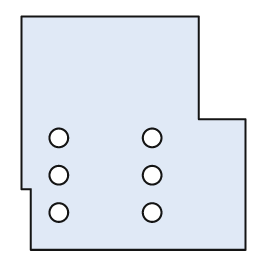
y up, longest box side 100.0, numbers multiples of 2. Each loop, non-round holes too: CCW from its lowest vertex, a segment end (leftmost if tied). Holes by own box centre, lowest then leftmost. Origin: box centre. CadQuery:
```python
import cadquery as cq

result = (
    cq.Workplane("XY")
    .moveTo(-44.0, -50.0)
    .lineTo(48.0, -50.0)
    .lineTo(48.0, 6.0)
    .lineTo(28.0, 6.0)
    .lineTo(28.0, 50.0)
    .lineTo(-48.0, 50.0)
    .lineTo(-48.0, -24.0)
    .lineTo(-44.0, -24.0)
    .close()
    .moveTo(-32.0, -34.0)
    .circle(4.0)
    .moveTo(8.0, -34.0)
    .circle(4.0)
    .moveTo(-32.0, -18.0)
    .circle(4.0)
    .moveTo(8.0, -18.0)
    .circle(4.0)
    .moveTo(-32.0, -2.0)
    .circle(4.0)
    .moveTo(8.0, -2.0)
    .circle(4.0)
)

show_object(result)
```